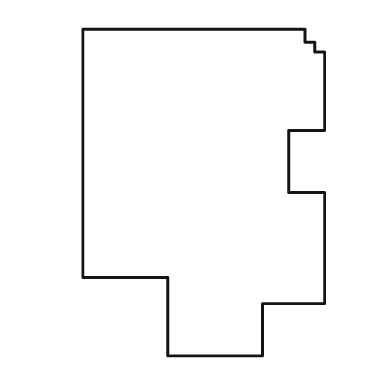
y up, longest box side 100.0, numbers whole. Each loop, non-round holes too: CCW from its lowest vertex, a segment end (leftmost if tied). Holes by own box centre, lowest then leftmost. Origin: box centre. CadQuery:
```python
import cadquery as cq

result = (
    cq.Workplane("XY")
    .moveTo(-11.0, -50.0)
    .lineTo(18.0, -50.0)
    .lineTo(18.0, -34.0)
    .lineTo(37.0, -34.0)
    .lineTo(37.0, 0.0)
    .lineTo(26.0, 0.0)
    .lineTo(26.0, 19.0)
    .lineTo(37.0, 19.0)
    .lineTo(37.0, 43.0)
    .lineTo(34.0, 43.0)
    .lineTo(34.0, 46.0)
    .lineTo(31.0, 46.0)
    .lineTo(31.0, 50.0)
    .lineTo(-37.0, 50.0)
    .lineTo(-37.0, -26.0)
    .lineTo(-11.0, -26.0)
    .close()
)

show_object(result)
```